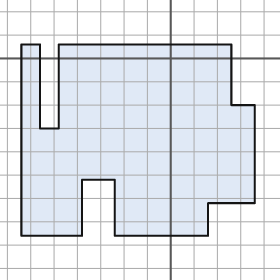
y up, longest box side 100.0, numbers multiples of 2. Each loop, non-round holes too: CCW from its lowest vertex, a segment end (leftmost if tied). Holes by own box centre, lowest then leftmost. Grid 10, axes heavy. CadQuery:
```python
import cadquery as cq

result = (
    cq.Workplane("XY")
    .moveTo(-64.0, -76.0)
    .lineTo(-38.0, -76.0)
    .lineTo(-38.0, -52.0)
    .lineTo(-24.0, -52.0)
    .lineTo(-24.0, -76.0)
    .lineTo(16.0, -76.0)
    .lineTo(16.0, -62.0)
    .lineTo(36.0, -62.0)
    .lineTo(36.0, -20.0)
    .lineTo(26.0, -20.0)
    .lineTo(26.0, 6.0)
    .lineTo(-48.0, 6.0)
    .lineTo(-48.0, -30.0)
    .lineTo(-56.0, -30.0)
    .lineTo(-56.0, 6.0)
    .lineTo(-64.0, 6.0)
    .close()
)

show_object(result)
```